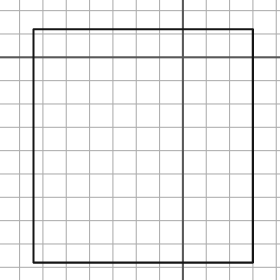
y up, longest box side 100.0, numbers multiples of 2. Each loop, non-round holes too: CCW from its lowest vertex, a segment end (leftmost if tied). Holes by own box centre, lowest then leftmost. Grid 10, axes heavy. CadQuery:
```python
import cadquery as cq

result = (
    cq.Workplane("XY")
    .moveTo(-64.0, -88.0)
    .lineTo(30.0, -88.0)
    .lineTo(30.0, 12.0)
    .lineTo(-64.0, 12.0)
    .close()
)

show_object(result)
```